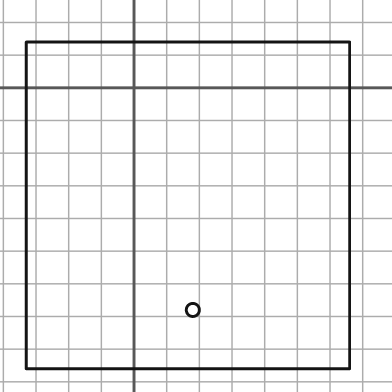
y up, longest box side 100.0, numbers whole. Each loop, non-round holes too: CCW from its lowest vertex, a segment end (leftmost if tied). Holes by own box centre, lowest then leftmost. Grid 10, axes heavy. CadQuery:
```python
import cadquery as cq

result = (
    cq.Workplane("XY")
    .moveTo(-33.0, -86.0)
    .lineTo(66.0, -86.0)
    .lineTo(66.0, 14.0)
    .lineTo(-33.0, 14.0)
    .close()
    .moveTo(18.0, -68.0)
    .circle(2.0)
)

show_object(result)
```